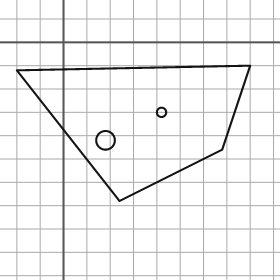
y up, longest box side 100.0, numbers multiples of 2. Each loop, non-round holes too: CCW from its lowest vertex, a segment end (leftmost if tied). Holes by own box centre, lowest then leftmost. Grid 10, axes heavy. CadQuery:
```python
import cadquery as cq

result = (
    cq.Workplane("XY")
    .moveTo(24.0, -68.0)
    .lineTo(68.0, -46.0)
    .lineTo(80.0, -10.0)
    .lineTo(-20.0, -12.0)
    .close()
    .moveTo(18.0, -42.0)
    .circle(4.0)
    .moveTo(42.0, -30.0)
    .circle(2.0)
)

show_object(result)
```